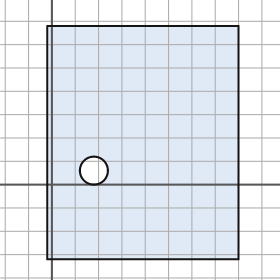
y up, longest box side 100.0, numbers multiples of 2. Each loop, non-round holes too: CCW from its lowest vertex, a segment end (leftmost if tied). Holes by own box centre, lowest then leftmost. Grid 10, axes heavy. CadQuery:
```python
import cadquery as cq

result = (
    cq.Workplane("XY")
    .moveTo(-2.0, -32.0)
    .lineTo(80.0, -32.0)
    .lineTo(80.0, 68.0)
    .lineTo(-2.0, 68.0)
    .close()
    .moveTo(18.0, 6.0)
    .circle(6.0)
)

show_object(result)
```